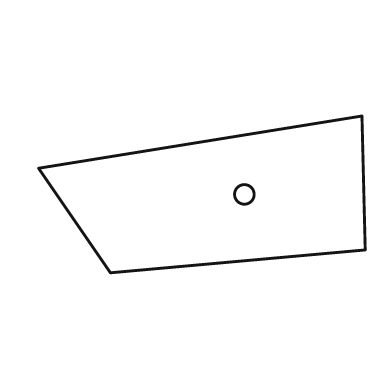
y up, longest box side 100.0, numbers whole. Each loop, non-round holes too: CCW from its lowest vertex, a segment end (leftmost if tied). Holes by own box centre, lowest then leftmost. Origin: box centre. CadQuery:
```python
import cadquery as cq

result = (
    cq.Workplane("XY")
    .moveTo(-28.0, -24.0)
    .lineTo(50.0, -17.0)
    .lineTo(49.0, 24.0)
    .lineTo(-50.0, 8.0)
    .close()
    .moveTo(13.0, 0.0)
    .circle(3.0)
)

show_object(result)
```